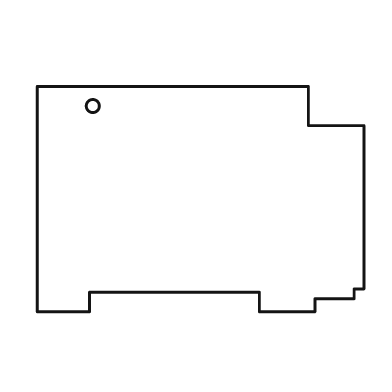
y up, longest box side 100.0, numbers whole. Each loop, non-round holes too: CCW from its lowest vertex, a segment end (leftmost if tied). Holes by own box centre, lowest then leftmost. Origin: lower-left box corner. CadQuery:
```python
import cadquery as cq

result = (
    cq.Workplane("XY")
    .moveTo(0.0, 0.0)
    .lineTo(16.0, 0.0)
    .lineTo(16.0, 6.0)
    .lineTo(68.0, 6.0)
    .lineTo(68.0, 0.0)
    .lineTo(85.0, 0.0)
    .lineTo(85.0, 4.0)
    .lineTo(97.0, 4.0)
    .lineTo(97.0, 7.0)
    .lineTo(100.0, 7.0)
    .lineTo(100.0, 57.0)
    .lineTo(83.0, 57.0)
    .lineTo(83.0, 69.0)
    .lineTo(0.0, 69.0)
    .close()
    .moveTo(17.0, 63.0)
    .circle(2.0)
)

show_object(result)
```